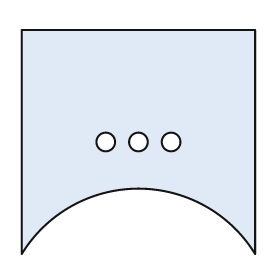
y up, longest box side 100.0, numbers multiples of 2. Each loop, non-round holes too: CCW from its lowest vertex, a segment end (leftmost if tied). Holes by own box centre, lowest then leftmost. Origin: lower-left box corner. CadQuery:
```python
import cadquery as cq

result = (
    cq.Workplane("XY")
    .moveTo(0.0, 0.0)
    .threePointArc((50.0, 28.0), (100.0, 0.0))
    .lineTo(100.0, 96.0)
    .lineTo(0.0, 96.0)
    .close()
    .moveTo(36.0, 48.0)
    .circle(4.0)
    .moveTo(50.0, 48.0)
    .circle(4.0)
    .moveTo(64.0, 48.0)
    .circle(4.0)
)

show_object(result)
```